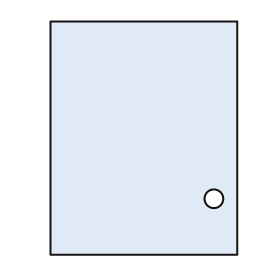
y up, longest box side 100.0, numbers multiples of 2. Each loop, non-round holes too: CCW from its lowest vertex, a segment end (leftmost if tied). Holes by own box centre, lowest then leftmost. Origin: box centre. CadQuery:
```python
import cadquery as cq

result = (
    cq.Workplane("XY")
    .moveTo(-40.0, -50.0)
    .lineTo(40.0, -50.0)
    .lineTo(40.0, 50.0)
    .lineTo(-40.0, 50.0)
    .close()
    .moveTo(30.0, -26.0)
    .circle(4.0)
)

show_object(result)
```